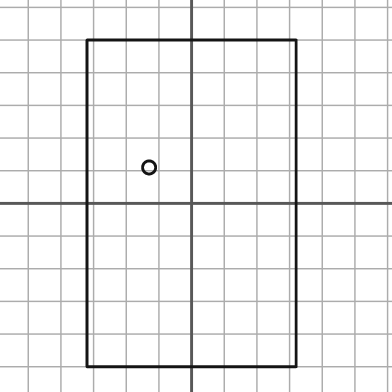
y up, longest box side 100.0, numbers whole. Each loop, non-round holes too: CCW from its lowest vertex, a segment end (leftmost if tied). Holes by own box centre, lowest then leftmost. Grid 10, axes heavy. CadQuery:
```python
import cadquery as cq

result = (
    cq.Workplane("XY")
    .moveTo(-32.0, -50.0)
    .lineTo(32.0, -50.0)
    .lineTo(32.0, 50.0)
    .lineTo(-32.0, 50.0)
    .close()
    .moveTo(-13.0, 11.0)
    .circle(2.0)
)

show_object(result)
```